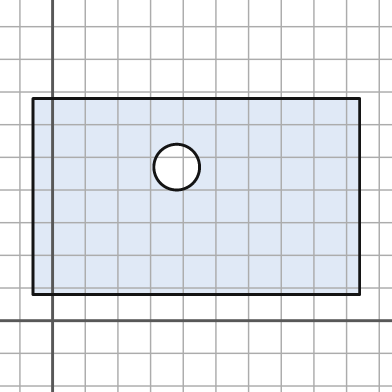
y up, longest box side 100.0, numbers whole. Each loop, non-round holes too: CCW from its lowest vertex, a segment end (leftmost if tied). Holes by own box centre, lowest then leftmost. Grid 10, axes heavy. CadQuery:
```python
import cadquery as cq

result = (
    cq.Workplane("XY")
    .moveTo(-6.0, 8.0)
    .lineTo(94.0, 8.0)
    .lineTo(94.0, 68.0)
    .lineTo(-6.0, 68.0)
    .close()
    .moveTo(38.0, 47.0)
    .circle(7.0)
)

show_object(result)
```